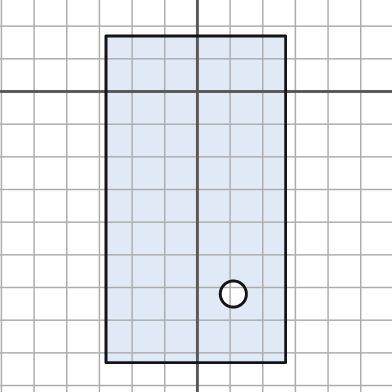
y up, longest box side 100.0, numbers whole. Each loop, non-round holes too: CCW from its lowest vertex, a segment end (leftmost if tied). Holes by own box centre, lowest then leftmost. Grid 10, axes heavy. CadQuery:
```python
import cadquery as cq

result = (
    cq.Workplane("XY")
    .moveTo(-28.0, -83.0)
    .lineTo(27.0, -83.0)
    .lineTo(27.0, 17.0)
    .lineTo(-28.0, 17.0)
    .close()
    .moveTo(11.0, -62.0)
    .circle(4.0)
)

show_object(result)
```